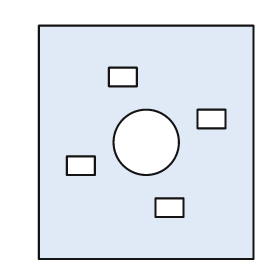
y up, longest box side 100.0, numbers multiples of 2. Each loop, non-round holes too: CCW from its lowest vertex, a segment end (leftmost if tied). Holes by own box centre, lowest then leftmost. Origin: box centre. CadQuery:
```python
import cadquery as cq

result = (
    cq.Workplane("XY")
    .moveTo(-46.0, -50.0)
    .lineTo(46.0, -50.0)
    .lineTo(46.0, 50.0)
    .lineTo(-46.0, 50.0)
    .close()
    .moveTo(4.0, -32.0)
    .lineTo(16.0, -32.0)
    .lineTo(16.0, -24.0)
    .lineTo(4.0, -24.0)
    .close()
    .moveTo(-34.0, -14.0)
    .lineTo(-22.0, -14.0)
    .lineTo(-22.0, -6.0)
    .lineTo(-34.0, -6.0)
    .close()
    .moveTo(0.0, 0.0)
    .circle(14.0)
    .moveTo(22.0, 6.0)
    .lineTo(34.0, 6.0)
    .lineTo(34.0, 14.0)
    .lineTo(22.0, 14.0)
    .close()
    .moveTo(-16.0, 24.0)
    .lineTo(-4.0, 24.0)
    .lineTo(-4.0, 32.0)
    .lineTo(-16.0, 32.0)
    .close()
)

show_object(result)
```